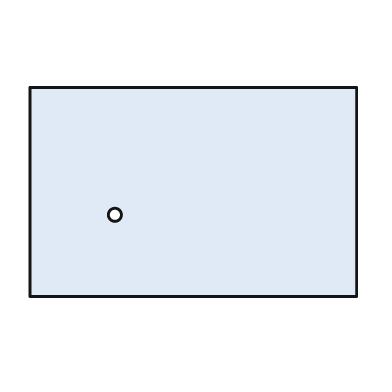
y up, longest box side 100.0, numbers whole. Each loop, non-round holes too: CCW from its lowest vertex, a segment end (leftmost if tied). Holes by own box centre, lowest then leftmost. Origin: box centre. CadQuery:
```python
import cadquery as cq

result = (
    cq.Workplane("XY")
    .moveTo(-50.0, -32.0)
    .lineTo(50.0, -32.0)
    .lineTo(50.0, 32.0)
    .lineTo(-50.0, 32.0)
    .close()
    .moveTo(-24.0, -7.0)
    .circle(2.0)
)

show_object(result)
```